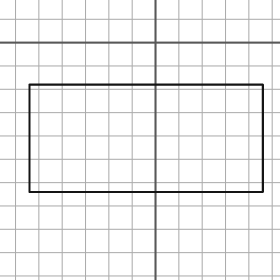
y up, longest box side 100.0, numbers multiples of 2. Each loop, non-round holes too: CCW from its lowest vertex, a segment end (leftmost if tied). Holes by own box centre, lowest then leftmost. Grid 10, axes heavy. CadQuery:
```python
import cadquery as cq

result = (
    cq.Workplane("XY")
    .moveTo(-54.0, -64.0)
    .lineTo(46.0, -64.0)
    .lineTo(46.0, -18.0)
    .lineTo(-54.0, -18.0)
    .close()
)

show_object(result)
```